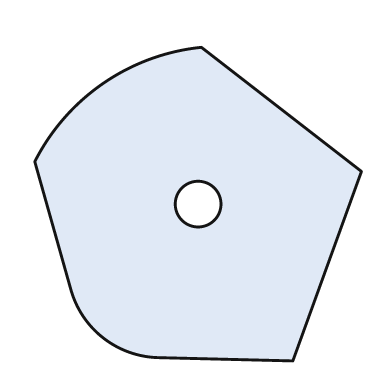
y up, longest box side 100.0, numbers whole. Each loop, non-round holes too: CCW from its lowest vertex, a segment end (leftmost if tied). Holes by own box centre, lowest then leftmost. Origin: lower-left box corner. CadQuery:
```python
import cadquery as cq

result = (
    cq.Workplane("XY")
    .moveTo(79.0, 0.0)
    .lineTo(100.0, 58.0)
    .lineTo(51.0, 96.0)
    .threePointArc((21.0, 85.0), (0.0, 61.0))
    .lineTo(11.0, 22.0)
    .threePointArc((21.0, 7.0), (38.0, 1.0))
    .close()
    .moveTo(50.0, 48.0)
    .circle(7.0)
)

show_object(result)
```